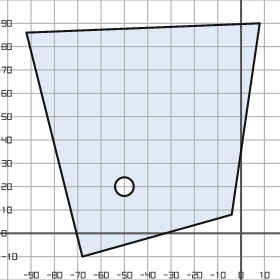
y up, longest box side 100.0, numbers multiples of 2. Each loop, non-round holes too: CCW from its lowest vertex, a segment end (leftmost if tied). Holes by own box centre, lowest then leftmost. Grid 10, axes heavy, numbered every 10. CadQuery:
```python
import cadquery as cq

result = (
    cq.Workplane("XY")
    .moveTo(-68.0, -10.0)
    .lineTo(-4.0, 8.0)
    .lineTo(8.0, 90.0)
    .lineTo(-92.0, 86.0)
    .close()
    .moveTo(-50.0, 20.0)
    .circle(4.0)
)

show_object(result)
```